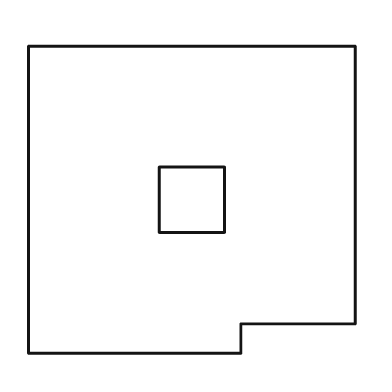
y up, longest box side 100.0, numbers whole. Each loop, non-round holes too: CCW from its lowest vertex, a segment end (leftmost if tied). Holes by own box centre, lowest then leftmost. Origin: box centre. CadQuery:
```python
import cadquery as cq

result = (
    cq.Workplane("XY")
    .moveTo(-50.0, -47.0)
    .lineTo(15.0, -47.0)
    .lineTo(15.0, -38.0)
    .lineTo(50.0, -38.0)
    .lineTo(50.0, 47.0)
    .lineTo(-50.0, 47.0)
    .close()
    .moveTo(-10.0, -10.0)
    .lineTo(10.0, -10.0)
    .lineTo(10.0, 10.0)
    .lineTo(-10.0, 10.0)
    .close()
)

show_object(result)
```